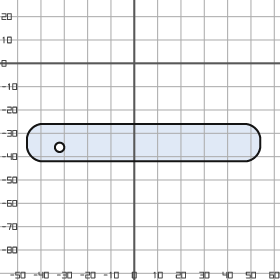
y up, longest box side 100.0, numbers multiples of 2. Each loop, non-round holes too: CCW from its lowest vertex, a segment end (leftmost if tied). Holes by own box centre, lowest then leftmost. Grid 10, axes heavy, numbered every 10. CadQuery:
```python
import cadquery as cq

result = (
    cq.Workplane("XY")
    .moveTo(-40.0, -42.0)
    .lineTo(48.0, -42.0)
    .threePointArc((52.0, -40.0), (54.0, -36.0))
    .lineTo(54.0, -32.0)
    .threePointArc((52.0, -28.0), (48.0, -26.0))
    .lineTo(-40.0, -26.0)
    .threePointArc((-44.0, -28.0), (-46.0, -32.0))
    .lineTo(-46.0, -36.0)
    .threePointArc((-44.0, -40.0), (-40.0, -42.0))
    .close()
    .moveTo(-32.0, -36.0)
    .circle(2.0)
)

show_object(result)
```